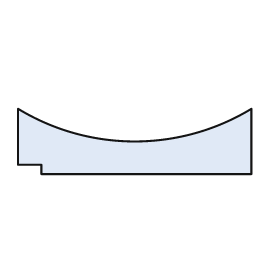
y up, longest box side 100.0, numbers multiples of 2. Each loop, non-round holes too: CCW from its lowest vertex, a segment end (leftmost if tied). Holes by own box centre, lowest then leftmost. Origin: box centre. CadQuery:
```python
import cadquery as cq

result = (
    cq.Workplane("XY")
    .moveTo(-40.0, -14.0)
    .lineTo(50.0, -14.0)
    .lineTo(50.0, 14.0)
    .threePointArc((0.0, 0.0), (-50.0, 14.0))
    .lineTo(-50.0, -10.0)
    .lineTo(-40.0, -10.0)
    .close()
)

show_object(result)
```